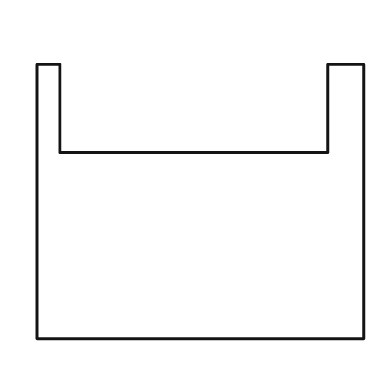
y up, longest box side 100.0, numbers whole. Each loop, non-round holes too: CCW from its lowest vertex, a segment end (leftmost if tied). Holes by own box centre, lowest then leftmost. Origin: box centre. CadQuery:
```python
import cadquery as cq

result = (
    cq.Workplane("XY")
    .moveTo(-50.0, -42.0)
    .lineTo(50.0, -42.0)
    .lineTo(50.0, 42.0)
    .lineTo(39.0, 42.0)
    .lineTo(39.0, 15.0)
    .lineTo(-43.0, 15.0)
    .lineTo(-43.0, 42.0)
    .lineTo(-50.0, 42.0)
    .close()
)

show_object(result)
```